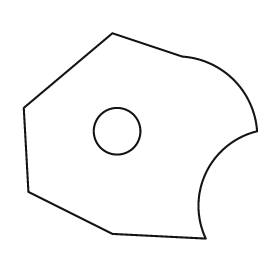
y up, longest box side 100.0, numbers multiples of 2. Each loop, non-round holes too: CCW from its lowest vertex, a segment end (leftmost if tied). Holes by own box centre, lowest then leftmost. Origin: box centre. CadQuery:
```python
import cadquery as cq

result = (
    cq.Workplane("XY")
    .moveTo(28.0, -44.0)
    .threePointArc((28.0, -16.0), (50.0, 2.0))
    .threePointArc((40.0, 24.0), (18.0, 34.0))
    .lineTo(-12.0, 44.0)
    .lineTo(-50.0, 12.0)
    .lineTo(-48.0, -24.0)
    .lineTo(-12.0, -42.0)
    .close()
    .moveTo(-10.0, 2.0)
    .circle(10.0)
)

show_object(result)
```